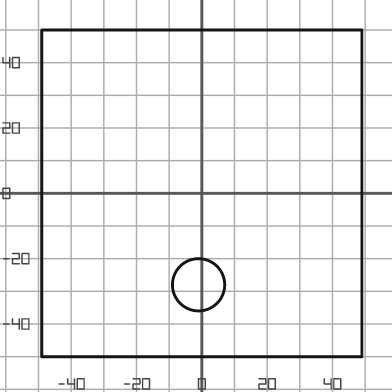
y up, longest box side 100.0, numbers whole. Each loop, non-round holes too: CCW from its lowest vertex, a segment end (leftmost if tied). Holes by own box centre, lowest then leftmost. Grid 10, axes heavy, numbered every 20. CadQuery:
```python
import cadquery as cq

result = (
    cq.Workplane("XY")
    .moveTo(-49.0, -50.0)
    .lineTo(49.0, -50.0)
    .lineTo(49.0, 50.0)
    .lineTo(-49.0, 50.0)
    .close()
    .moveTo(-1.0, -28.0)
    .circle(8.0)
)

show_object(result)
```